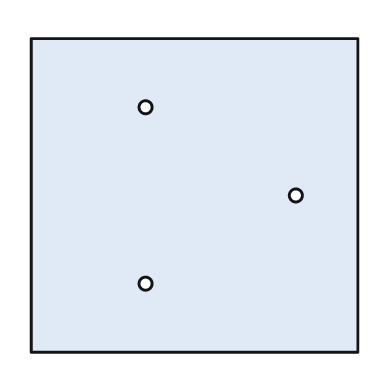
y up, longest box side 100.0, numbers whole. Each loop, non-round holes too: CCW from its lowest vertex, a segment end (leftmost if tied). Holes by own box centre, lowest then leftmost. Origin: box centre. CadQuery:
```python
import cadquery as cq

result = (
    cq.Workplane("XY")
    .moveTo(-50.0, -48.0)
    .lineTo(50.0, -48.0)
    .lineTo(50.0, 48.0)
    .lineTo(-50.0, 48.0)
    .close()
    .moveTo(-15.0, -27.0)
    .circle(2.0)
    .moveTo(31.0, 0.0)
    .circle(2.0)
    .moveTo(-15.0, 27.0)
    .circle(2.0)
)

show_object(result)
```